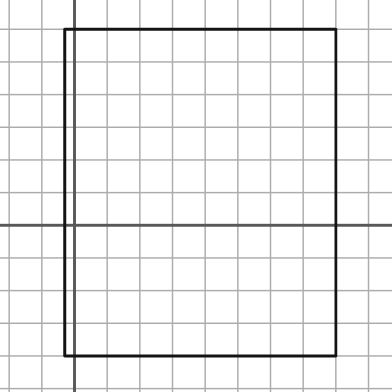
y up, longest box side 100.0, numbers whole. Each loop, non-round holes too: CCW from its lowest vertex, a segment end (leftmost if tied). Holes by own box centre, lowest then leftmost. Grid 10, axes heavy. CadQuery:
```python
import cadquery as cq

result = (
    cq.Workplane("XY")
    .moveTo(-3.0, -40.0)
    .lineTo(80.0, -40.0)
    .lineTo(80.0, 60.0)
    .lineTo(-3.0, 60.0)
    .close()
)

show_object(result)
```